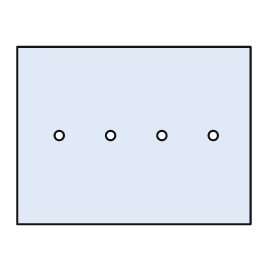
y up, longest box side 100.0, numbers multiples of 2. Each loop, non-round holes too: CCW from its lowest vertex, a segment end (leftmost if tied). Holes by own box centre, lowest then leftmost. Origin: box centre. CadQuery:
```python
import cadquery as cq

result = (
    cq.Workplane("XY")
    .moveTo(-50.0, -38.0)
    .lineTo(50.0, -38.0)
    .lineTo(50.0, 38.0)
    .lineTo(-50.0, 38.0)
    .close()
    .moveTo(-32.0, 0.0)
    .circle(2.0)
    .moveTo(-10.0, 0.0)
    .circle(2.0)
    .moveTo(12.0, 0.0)
    .circle(2.0)
    .moveTo(34.0, 0.0)
    .circle(2.0)
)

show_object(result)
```